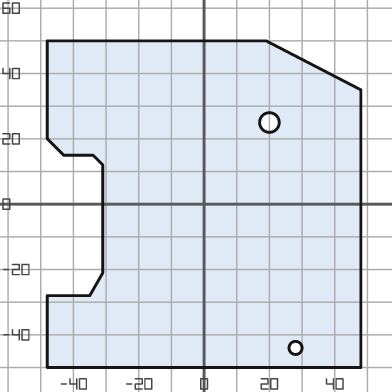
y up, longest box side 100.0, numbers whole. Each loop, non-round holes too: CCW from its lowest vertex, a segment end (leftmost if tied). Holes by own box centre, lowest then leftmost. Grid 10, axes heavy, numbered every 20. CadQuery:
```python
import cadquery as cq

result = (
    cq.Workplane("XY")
    .moveTo(-48.0, -50.0)
    .lineTo(48.0, -50.0)
    .lineTo(48.0, 35.0)
    .lineTo(19.0, 50.0)
    .lineTo(-48.0, 50.0)
    .lineTo(-48.0, 20.0)
    .lineTo(-43.0, 15.0)
    .lineTo(-34.0, 15.0)
    .lineTo(-31.0, 12.0)
    .lineTo(-31.0, -21.0)
    .lineTo(-35.0, -28.0)
    .lineTo(-48.0, -28.0)
    .close()
    .moveTo(28.0, -44.0)
    .circle(2.0)
    .moveTo(20.0, 25.0)
    .circle(3.0)
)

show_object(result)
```